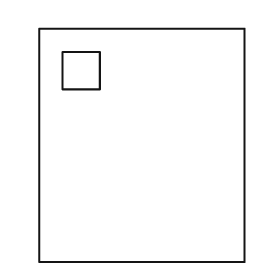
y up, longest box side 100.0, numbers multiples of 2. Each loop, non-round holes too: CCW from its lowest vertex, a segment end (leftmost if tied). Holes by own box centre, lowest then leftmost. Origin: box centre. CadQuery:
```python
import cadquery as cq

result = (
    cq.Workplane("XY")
    .moveTo(-44.0, -50.0)
    .lineTo(44.0, -50.0)
    .lineTo(44.0, 50.0)
    .lineTo(-44.0, 50.0)
    .close()
    .moveTo(-34.0, 24.0)
    .lineTo(-18.0, 24.0)
    .lineTo(-18.0, 40.0)
    .lineTo(-34.0, 40.0)
    .close()
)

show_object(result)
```